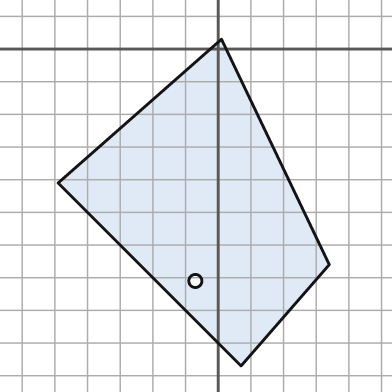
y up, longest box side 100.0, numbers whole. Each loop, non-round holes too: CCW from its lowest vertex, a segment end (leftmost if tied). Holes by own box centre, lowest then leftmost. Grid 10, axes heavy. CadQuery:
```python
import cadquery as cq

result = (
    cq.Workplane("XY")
    .moveTo(7.0, -97.0)
    .lineTo(34.0, -66.0)
    .lineTo(1.0, 3.0)
    .lineTo(-49.0, -41.0)
    .close()
    .moveTo(-7.0, -71.0)
    .circle(2.0)
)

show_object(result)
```